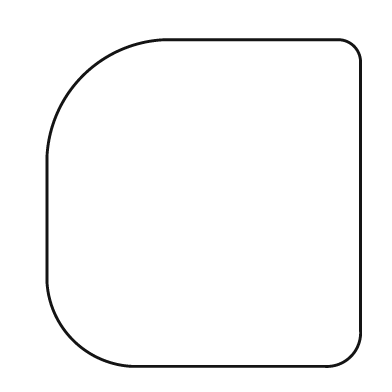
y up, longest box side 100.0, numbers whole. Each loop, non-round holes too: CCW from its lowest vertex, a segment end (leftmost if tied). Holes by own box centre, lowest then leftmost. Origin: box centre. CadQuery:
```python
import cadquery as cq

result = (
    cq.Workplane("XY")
    .moveTo(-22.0, -50.0)
    .lineTo(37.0, -50.0)
    .threePointArc((45.0, -47.0), (48.0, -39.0))
    .lineTo(48.0, 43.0)
    .threePointArc((46.0, 48.0), (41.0, 50.0))
    .lineTo(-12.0, 50.0)
    .threePointArc((-37.0, 39.0), (-48.0, 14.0))
    .lineTo(-48.0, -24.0)
    .threePointArc((-40.0, -42.0), (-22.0, -50.0))
    .close()
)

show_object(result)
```